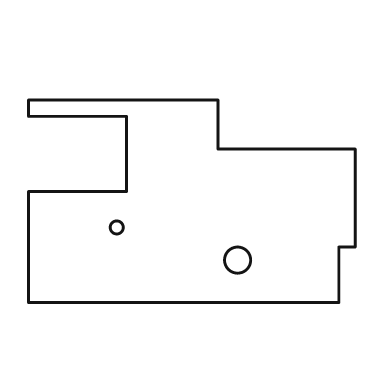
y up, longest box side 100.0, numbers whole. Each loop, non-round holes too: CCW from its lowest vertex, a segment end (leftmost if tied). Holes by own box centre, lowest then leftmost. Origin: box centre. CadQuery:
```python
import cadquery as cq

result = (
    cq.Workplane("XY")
    .moveTo(-50.0, -31.0)
    .lineTo(45.0, -31.0)
    .lineTo(45.0, -14.0)
    .lineTo(50.0, -14.0)
    .lineTo(50.0, 16.0)
    .lineTo(8.0, 16.0)
    .lineTo(8.0, 31.0)
    .lineTo(-50.0, 31.0)
    .lineTo(-50.0, 26.0)
    .lineTo(-20.0, 26.0)
    .lineTo(-20.0, 3.0)
    .lineTo(-50.0, 3.0)
    .close()
    .moveTo(14.0, -18.0)
    .circle(4.0)
    .moveTo(-23.0, -8.0)
    .circle(2.0)
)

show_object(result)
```